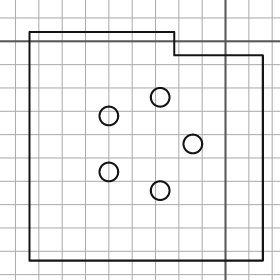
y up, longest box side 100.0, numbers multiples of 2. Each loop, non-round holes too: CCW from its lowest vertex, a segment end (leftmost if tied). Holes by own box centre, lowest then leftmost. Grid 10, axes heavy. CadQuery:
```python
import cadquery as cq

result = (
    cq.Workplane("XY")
    .moveTo(-84.0, -94.0)
    .lineTo(16.0, -94.0)
    .lineTo(16.0, -6.0)
    .lineTo(-22.0, -6.0)
    .lineTo(-22.0, 4.0)
    .lineTo(-84.0, 4.0)
    .close()
    .moveTo(-28.0, -64.0)
    .circle(4.0)
    .moveTo(-50.0, -56.0)
    .circle(4.0)
    .moveTo(-14.0, -44.0)
    .circle(4.0)
    .moveTo(-50.0, -32.0)
    .circle(4.0)
    .moveTo(-28.0, -24.0)
    .circle(4.0)
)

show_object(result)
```